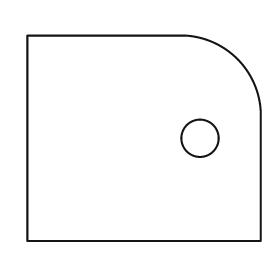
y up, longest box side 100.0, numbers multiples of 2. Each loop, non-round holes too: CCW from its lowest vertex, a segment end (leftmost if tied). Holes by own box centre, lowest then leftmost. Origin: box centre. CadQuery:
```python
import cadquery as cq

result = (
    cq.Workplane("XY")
    .moveTo(-50.0, -44.0)
    .lineTo(50.0, -44.0)
    .lineTo(50.0, 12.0)
    .threePointArc((40.0, 34.0), (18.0, 44.0))
    .lineTo(-50.0, 44.0)
    .close()
    .moveTo(24.0, 0.0)
    .circle(8.0)
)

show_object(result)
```